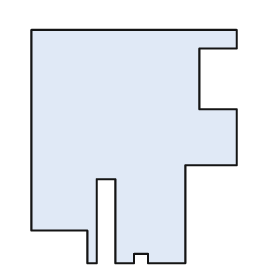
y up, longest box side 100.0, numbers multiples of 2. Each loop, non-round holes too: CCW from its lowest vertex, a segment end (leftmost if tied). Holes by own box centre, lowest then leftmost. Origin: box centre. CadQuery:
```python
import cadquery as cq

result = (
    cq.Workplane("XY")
    .moveTo(-20.0, -50.0)
    .lineTo(-16.0, -50.0)
    .lineTo(-16.0, -14.0)
    .lineTo(-8.0, -14.0)
    .lineTo(-8.0, -50.0)
    .lineTo(0.0, -50.0)
    .lineTo(0.0, -46.0)
    .lineTo(6.0, -46.0)
    .lineTo(6.0, -50.0)
    .lineTo(22.0, -50.0)
    .lineTo(22.0, -8.0)
    .lineTo(44.0, -8.0)
    .lineTo(44.0, 16.0)
    .lineTo(28.0, 16.0)
    .lineTo(28.0, 42.0)
    .lineTo(44.0, 42.0)
    .lineTo(44.0, 50.0)
    .lineTo(-44.0, 50.0)
    .lineTo(-44.0, -36.0)
    .lineTo(-20.0, -36.0)
    .close()
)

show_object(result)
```